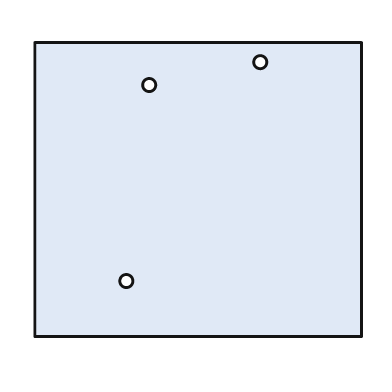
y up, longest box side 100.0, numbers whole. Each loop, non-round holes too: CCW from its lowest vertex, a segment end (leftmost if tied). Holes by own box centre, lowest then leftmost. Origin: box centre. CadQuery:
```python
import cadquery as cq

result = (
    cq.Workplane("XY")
    .moveTo(-50.0, -45.0)
    .lineTo(50.0, -45.0)
    .lineTo(50.0, 45.0)
    .lineTo(-50.0, 45.0)
    .close()
    .moveTo(-22.0, -28.0)
    .circle(2.0)
    .moveTo(-15.0, 32.0)
    .circle(2.0)
    .moveTo(19.0, 39.0)
    .circle(2.0)
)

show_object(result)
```